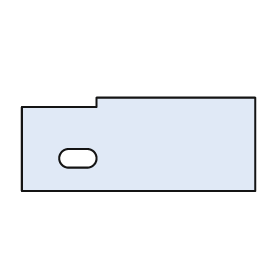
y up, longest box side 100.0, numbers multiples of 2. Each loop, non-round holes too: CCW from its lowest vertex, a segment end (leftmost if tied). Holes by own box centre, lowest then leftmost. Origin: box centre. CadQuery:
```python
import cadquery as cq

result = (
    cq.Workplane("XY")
    .moveTo(-50.0, -20.0)
    .lineTo(50.0, -20.0)
    .lineTo(50.0, 20.0)
    .lineTo(-18.0, 20.0)
    .lineTo(-18.0, 16.0)
    .lineTo(-50.0, 16.0)
    .close()
    .moveTo(-30.0, -10.0)
    .lineTo(-22.0, -10.0)
    .threePointArc((-18.0, -6.0), (-22.0, -2.0))
    .lineTo(-30.0, -2.0)
    .threePointArc((-34.0, -6.0), (-30.0, -10.0))
    .close()
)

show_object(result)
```